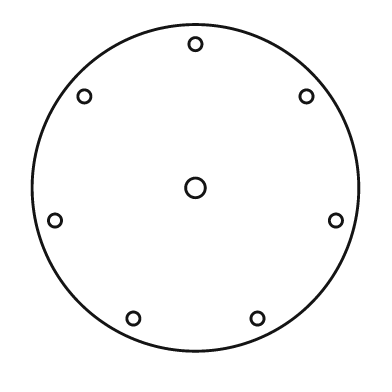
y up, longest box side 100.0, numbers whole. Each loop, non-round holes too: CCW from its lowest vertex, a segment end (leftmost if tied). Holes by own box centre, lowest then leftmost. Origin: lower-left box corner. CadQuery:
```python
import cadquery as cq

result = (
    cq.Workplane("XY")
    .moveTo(50.0, 50.0)
    .circle(50.0)
    .moveTo(31.0, 10.0)
    .circle(2.0)
    .moveTo(69.0, 10.0)
    .circle(2.0)
    .moveTo(7.0, 40.0)
    .circle(2.0)
    .moveTo(93.0, 40.0)
    .circle(2.0)
    .moveTo(50.0, 50.0)
    .circle(3.0)
    .moveTo(16.0, 78.0)
    .circle(2.0)
    .moveTo(84.0, 78.0)
    .circle(2.0)
    .moveTo(50.0, 94.0)
    .circle(2.0)
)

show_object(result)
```